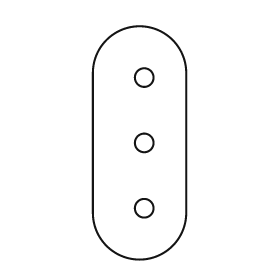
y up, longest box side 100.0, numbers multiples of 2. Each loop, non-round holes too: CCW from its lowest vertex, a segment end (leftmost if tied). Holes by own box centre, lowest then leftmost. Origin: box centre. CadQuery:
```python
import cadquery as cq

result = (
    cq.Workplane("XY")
    .moveTo(-20.0, -30.0)
    .threePointArc((0.0, -50.0), (20.0, -30.0))
    .lineTo(20.0, 30.0)
    .threePointArc((0.0, 50.0), (-20.0, 30.0))
    .close()
    .moveTo(2.0, -28.0)
    .circle(4.0)
    .moveTo(2.0, 0.0)
    .circle(4.0)
    .moveTo(2.0, 28.0)
    .circle(4.0)
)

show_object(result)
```